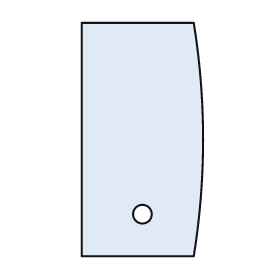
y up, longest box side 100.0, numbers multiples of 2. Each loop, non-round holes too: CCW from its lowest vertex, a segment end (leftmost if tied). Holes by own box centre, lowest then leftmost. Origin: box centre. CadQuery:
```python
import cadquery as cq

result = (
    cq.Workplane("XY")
    .moveTo(-26.0, -50.0)
    .lineTo(22.0, -50.0)
    .threePointArc((26.0, 0.0), (22.0, 50.0))
    .lineTo(-26.0, 50.0)
    .close()
    .moveTo(0.0, -32.0)
    .circle(4.0)
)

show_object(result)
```